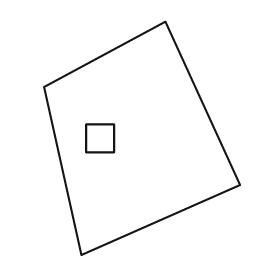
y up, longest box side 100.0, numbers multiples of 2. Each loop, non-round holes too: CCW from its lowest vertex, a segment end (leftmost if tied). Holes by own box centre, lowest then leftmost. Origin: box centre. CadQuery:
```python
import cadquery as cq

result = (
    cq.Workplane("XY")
    .moveTo(-26.0, -50.0)
    .lineTo(42.0, -20.0)
    .lineTo(10.0, 50.0)
    .lineTo(-42.0, 22.0)
    .close()
    .moveTo(-24.0, -6.0)
    .lineTo(-12.0, -6.0)
    .lineTo(-12.0, 6.0)
    .lineTo(-24.0, 6.0)
    .close()
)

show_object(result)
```